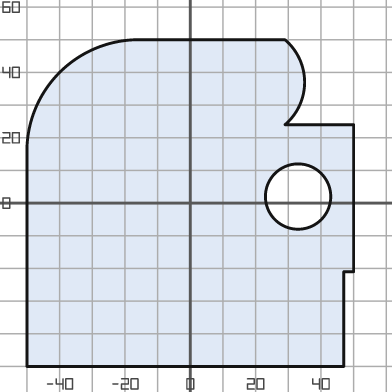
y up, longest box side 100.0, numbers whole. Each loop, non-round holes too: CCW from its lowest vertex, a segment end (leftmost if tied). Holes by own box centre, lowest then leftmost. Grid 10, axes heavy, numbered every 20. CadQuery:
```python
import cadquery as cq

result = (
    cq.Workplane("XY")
    .moveTo(-50.0, -50.0)
    .lineTo(47.0, -50.0)
    .lineTo(47.0, -21.0)
    .lineTo(50.0, -21.0)
    .lineTo(50.0, 24.0)
    .lineTo(29.0, 24.0)
    .threePointArc((35.0, 37.0), (29.0, 50.0))
    .lineTo(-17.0, 50.0)
    .threePointArc((-40.0, 40.0), (-50.0, 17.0))
    .close()
    .moveTo(33.0, 2.0)
    .circle(10.0)
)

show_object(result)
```